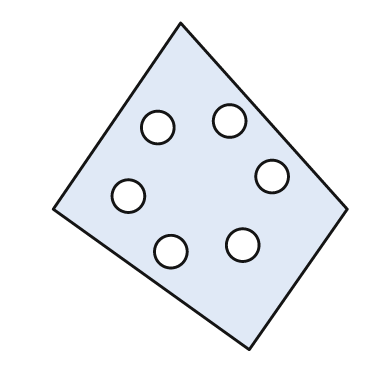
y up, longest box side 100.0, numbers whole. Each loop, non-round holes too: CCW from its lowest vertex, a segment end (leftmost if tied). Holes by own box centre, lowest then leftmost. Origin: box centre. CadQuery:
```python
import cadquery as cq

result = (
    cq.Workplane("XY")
    .moveTo(15.0, -50.0)
    .lineTo(45.0, -7.0)
    .lineTo(-6.0, 50.0)
    .lineTo(-45.0, -7.0)
    .close()
    .moveTo(-9.0, -20.0)
    .circle(5.0)
    .moveTo(13.0, -18.0)
    .circle(5.0)
    .moveTo(-22.0, -3.0)
    .circle(5.0)
    .moveTo(22.0, 3.0)
    .circle(5.0)
    .moveTo(-13.0, 18.0)
    .circle(5.0)
    .moveTo(9.0, 20.0)
    .circle(5.0)
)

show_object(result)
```